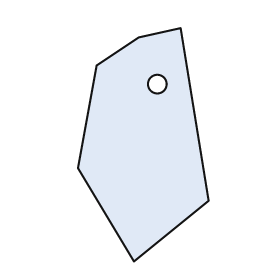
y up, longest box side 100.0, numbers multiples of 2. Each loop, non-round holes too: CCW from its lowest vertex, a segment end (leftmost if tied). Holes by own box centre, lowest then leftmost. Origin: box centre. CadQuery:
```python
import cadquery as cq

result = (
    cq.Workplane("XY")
    .moveTo(-4.0, -50.0)
    .lineTo(28.0, -24.0)
    .lineTo(16.0, 50.0)
    .lineTo(-2.0, 46.0)
    .lineTo(-20.0, 34.0)
    .lineTo(-28.0, -10.0)
    .close()
    .moveTo(6.0, 26.0)
    .circle(4.0)
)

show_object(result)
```